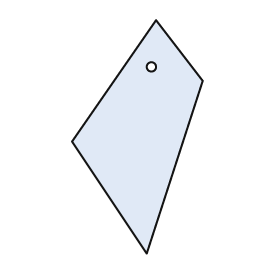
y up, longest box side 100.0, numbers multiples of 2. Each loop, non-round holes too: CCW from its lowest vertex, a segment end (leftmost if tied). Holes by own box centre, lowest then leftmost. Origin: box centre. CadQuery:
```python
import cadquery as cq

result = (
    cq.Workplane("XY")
    .moveTo(4.0, -50.0)
    .lineTo(28.0, 24.0)
    .lineTo(8.0, 50.0)
    .lineTo(-28.0, -2.0)
    .close()
    .moveTo(6.0, 30.0)
    .circle(2.0)
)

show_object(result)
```